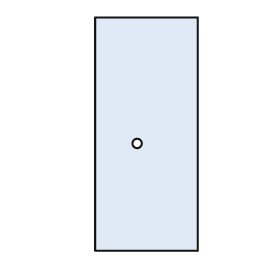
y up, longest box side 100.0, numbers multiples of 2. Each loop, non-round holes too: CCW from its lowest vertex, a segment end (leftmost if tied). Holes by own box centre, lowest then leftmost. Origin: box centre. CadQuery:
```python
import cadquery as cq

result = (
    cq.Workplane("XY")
    .moveTo(-22.0, -50.0)
    .lineTo(22.0, -50.0)
    .lineTo(22.0, 50.0)
    .lineTo(-22.0, 50.0)
    .close()
    .moveTo(-4.0, -4.0)
    .circle(2.0)
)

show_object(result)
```